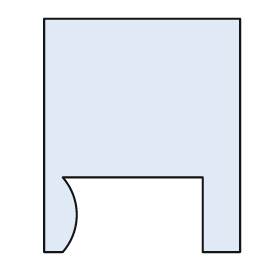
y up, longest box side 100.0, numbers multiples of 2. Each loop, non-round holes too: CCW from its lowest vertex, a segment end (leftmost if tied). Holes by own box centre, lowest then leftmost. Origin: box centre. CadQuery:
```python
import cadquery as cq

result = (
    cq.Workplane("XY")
    .moveTo(-42.0, -50.0)
    .lineTo(-34.0, -50.0)
    .threePointArc((-28.0, -34.0), (-34.0, -18.0))
    .lineTo(26.0, -18.0)
    .lineTo(26.0, -50.0)
    .lineTo(42.0, -50.0)
    .lineTo(42.0, 50.0)
    .lineTo(-42.0, 50.0)
    .close()
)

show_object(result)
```